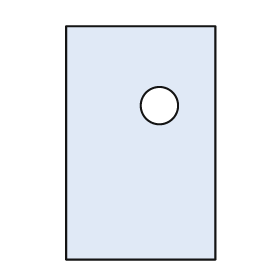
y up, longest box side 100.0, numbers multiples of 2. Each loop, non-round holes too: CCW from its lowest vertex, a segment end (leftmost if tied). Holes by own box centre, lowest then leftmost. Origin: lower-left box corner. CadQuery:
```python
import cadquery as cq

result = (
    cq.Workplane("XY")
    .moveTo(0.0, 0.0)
    .lineTo(64.0, 0.0)
    .lineTo(64.0, 100.0)
    .lineTo(0.0, 100.0)
    .close()
    .moveTo(40.0, 66.0)
    .circle(8.0)
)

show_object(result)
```